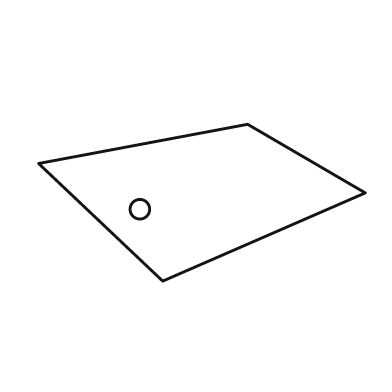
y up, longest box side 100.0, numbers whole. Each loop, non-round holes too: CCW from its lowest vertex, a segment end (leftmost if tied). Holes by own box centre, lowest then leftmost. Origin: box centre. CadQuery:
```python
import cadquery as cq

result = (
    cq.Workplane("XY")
    .moveTo(-12.0, -24.0)
    .lineTo(50.0, 3.0)
    .lineTo(14.0, 24.0)
    .lineTo(-50.0, 12.0)
    .close()
    .moveTo(-19.0, -2.0)
    .circle(3.0)
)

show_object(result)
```